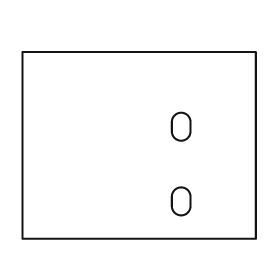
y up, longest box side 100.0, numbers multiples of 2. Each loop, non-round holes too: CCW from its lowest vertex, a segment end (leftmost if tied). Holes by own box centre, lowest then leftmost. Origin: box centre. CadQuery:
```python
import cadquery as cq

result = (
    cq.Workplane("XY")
    .moveTo(-50.0, -40.0)
    .lineTo(50.0, -40.0)
    .lineTo(50.0, 40.0)
    .lineTo(-50.0, 40.0)
    .close()
    .moveTo(14.0, -26.0)
    .threePointArc((18.0, -30.0), (22.0, -26.0))
    .lineTo(22.0, -22.0)
    .threePointArc((18.0, -18.0), (14.0, -22.0))
    .close()
    .moveTo(14.0, 6.0)
    .threePointArc((18.0, 2.0), (22.0, 6.0))
    .lineTo(22.0, 10.0)
    .threePointArc((18.0, 14.0), (14.0, 10.0))
    .close()
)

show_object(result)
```